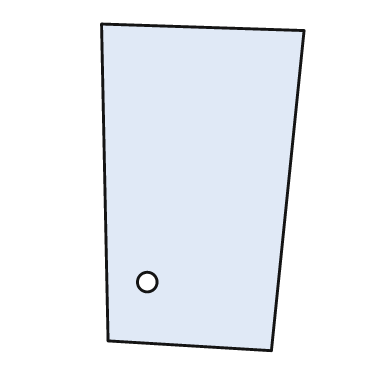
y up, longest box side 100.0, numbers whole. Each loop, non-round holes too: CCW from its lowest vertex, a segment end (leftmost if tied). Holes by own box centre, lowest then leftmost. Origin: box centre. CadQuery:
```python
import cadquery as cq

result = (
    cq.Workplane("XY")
    .moveTo(21.0, -50.0)
    .lineTo(31.0, 48.0)
    .lineTo(-31.0, 50.0)
    .lineTo(-29.0, -47.0)
    .close()
    .moveTo(-17.0, -29.0)
    .circle(3.0)
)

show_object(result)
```